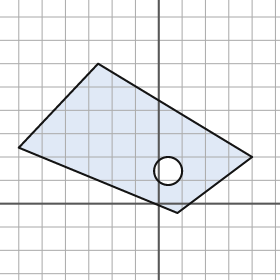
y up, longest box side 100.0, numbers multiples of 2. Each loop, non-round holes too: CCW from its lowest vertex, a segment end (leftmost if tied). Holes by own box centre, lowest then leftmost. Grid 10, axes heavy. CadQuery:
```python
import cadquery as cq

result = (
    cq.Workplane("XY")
    .moveTo(8.0, -4.0)
    .lineTo(40.0, 20.0)
    .lineTo(-26.0, 60.0)
    .lineTo(-60.0, 24.0)
    .close()
    .moveTo(4.0, 14.0)
    .circle(6.0)
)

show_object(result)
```